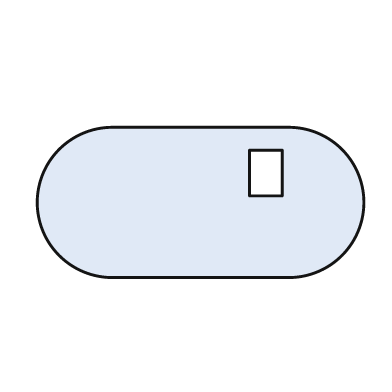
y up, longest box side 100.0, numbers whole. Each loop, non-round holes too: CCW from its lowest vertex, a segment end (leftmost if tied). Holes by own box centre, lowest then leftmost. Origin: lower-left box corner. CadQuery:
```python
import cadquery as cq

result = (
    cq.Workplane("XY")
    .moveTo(23.0, 0.0)
    .lineTo(77.0, 0.0)
    .threePointArc((100.0, 23.0), (77.0, 46.0))
    .lineTo(23.0, 46.0)
    .threePointArc((0.0, 23.0), (23.0, 0.0))
    .close()
    .moveTo(65.0, 25.0)
    .lineTo(75.0, 25.0)
    .lineTo(75.0, 39.0)
    .lineTo(65.0, 39.0)
    .close()
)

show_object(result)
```